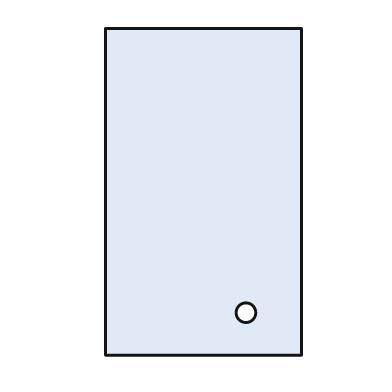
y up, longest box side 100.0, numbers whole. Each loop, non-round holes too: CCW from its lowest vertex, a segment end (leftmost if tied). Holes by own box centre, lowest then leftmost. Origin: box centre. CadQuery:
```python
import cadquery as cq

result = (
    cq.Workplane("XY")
    .moveTo(-30.0, -50.0)
    .lineTo(30.0, -50.0)
    .lineTo(30.0, 50.0)
    .lineTo(-30.0, 50.0)
    .close()
    .moveTo(13.0, -37.0)
    .circle(3.0)
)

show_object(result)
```